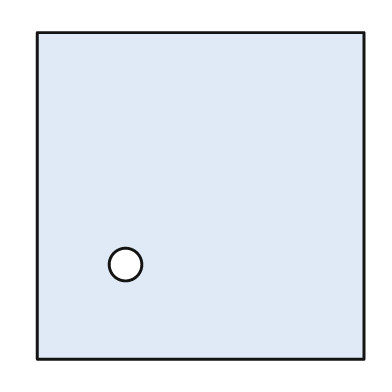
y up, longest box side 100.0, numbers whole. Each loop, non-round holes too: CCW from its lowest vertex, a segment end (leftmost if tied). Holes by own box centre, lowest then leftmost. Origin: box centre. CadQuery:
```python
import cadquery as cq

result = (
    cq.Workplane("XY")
    .moveTo(-50.0, -50.0)
    .lineTo(50.0, -50.0)
    .lineTo(50.0, 50.0)
    .lineTo(-50.0, 50.0)
    .close()
    .moveTo(-23.0, -21.0)
    .circle(5.0)
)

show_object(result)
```